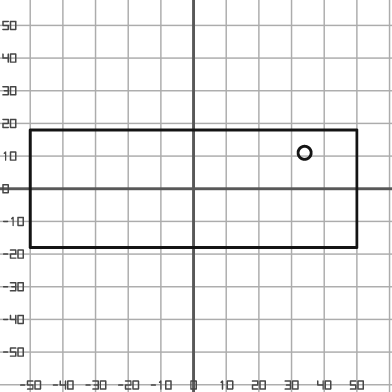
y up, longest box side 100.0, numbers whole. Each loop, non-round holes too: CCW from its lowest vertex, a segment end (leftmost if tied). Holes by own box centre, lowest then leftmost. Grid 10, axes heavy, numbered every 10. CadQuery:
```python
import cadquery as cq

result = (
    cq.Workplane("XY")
    .moveTo(-50.0, -18.0)
    .lineTo(50.0, -18.0)
    .lineTo(50.0, 18.0)
    .lineTo(-50.0, 18.0)
    .close()
    .moveTo(34.0, 11.0)
    .circle(2.0)
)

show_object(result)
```